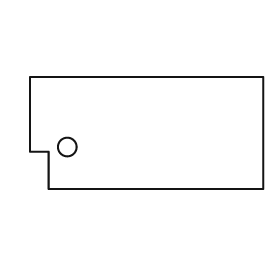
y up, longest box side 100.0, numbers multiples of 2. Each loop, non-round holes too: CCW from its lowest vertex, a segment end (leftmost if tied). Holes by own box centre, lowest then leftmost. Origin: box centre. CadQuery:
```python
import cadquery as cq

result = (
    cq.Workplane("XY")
    .moveTo(-42.0, -24.0)
    .lineTo(50.0, -24.0)
    .lineTo(50.0, 24.0)
    .lineTo(-50.0, 24.0)
    .lineTo(-50.0, -8.0)
    .lineTo(-42.0, -8.0)
    .close()
    .moveTo(-34.0, -6.0)
    .circle(4.0)
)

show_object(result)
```